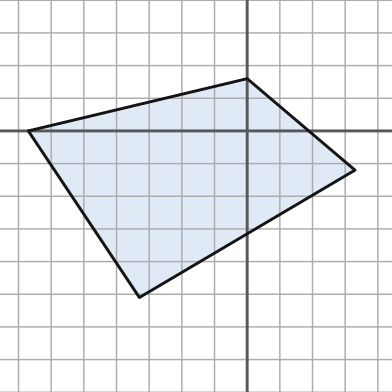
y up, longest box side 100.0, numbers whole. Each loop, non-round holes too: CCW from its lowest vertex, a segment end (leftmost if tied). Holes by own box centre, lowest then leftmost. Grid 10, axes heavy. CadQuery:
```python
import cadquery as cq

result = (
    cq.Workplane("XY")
    .moveTo(-33.0, -51.0)
    .lineTo(33.0, -12.0)
    .lineTo(0.0, 16.0)
    .lineTo(-67.0, 0.0)
    .close()
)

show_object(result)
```